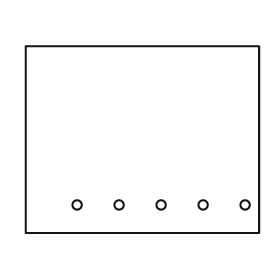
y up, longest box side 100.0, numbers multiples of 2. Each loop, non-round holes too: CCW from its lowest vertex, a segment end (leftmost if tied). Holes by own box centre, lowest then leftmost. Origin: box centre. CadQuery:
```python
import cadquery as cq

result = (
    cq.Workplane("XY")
    .moveTo(-50.0, -40.0)
    .lineTo(50.0, -40.0)
    .lineTo(50.0, 40.0)
    .lineTo(-50.0, 40.0)
    .close()
    .moveTo(-28.0, -28.0)
    .circle(2.0)
    .moveTo(-10.0, -28.0)
    .circle(2.0)
    .moveTo(8.0, -28.0)
    .circle(2.0)
    .moveTo(26.0, -28.0)
    .circle(2.0)
    .moveTo(44.0, -28.0)
    .circle(2.0)
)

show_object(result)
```